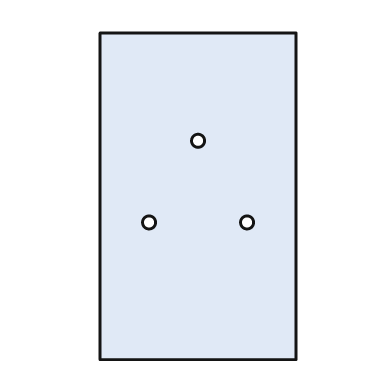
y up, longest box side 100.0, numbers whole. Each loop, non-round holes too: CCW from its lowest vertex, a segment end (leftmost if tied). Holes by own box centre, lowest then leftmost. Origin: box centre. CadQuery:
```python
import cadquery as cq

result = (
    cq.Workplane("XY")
    .moveTo(-30.0, -50.0)
    .lineTo(30.0, -50.0)
    .lineTo(30.0, 50.0)
    .lineTo(-30.0, 50.0)
    .close()
    .moveTo(-15.0, -8.0)
    .circle(2.0)
    .moveTo(15.0, -8.0)
    .circle(2.0)
    .moveTo(0.0, 17.0)
    .circle(2.0)
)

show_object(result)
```